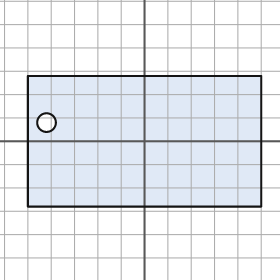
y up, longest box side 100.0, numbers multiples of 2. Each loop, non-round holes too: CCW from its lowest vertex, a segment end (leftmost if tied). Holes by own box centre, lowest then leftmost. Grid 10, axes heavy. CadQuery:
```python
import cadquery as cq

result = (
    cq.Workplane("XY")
    .moveTo(-50.0, -28.0)
    .lineTo(50.0, -28.0)
    .lineTo(50.0, 28.0)
    .lineTo(-50.0, 28.0)
    .close()
    .moveTo(-42.0, 8.0)
    .circle(4.0)
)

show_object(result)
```